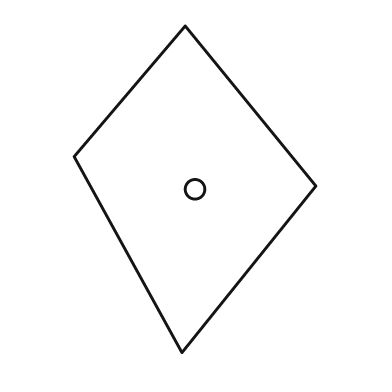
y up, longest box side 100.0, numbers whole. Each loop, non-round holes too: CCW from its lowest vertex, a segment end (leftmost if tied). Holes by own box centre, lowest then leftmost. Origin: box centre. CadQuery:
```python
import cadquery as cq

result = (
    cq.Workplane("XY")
    .moveTo(-4.0, -50.0)
    .lineTo(37.0, 1.0)
    .lineTo(-3.0, 50.0)
    .lineTo(-37.0, 10.0)
    .close()
    .moveTo(0.0, 0.0)
    .circle(3.0)
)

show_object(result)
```